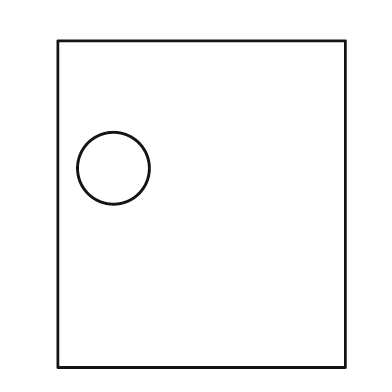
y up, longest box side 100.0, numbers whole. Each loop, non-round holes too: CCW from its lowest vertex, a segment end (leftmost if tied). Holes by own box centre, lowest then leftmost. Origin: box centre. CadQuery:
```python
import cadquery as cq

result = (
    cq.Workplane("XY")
    .moveTo(-44.0, -50.0)
    .lineTo(44.0, -50.0)
    .lineTo(44.0, 50.0)
    .lineTo(-44.0, 50.0)
    .close()
    .moveTo(-27.0, 11.0)
    .circle(11.0)
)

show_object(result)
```